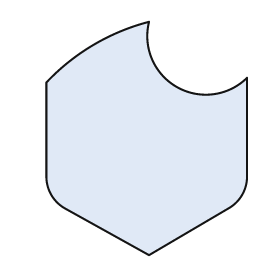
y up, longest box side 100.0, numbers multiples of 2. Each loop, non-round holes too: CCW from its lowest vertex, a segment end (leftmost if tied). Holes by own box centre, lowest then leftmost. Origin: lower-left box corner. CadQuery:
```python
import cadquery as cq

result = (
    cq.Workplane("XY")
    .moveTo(44.0, 0.0)
    .lineTo(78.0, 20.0)
    .threePointArc((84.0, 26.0), (86.0, 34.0))
    .lineTo(86.0, 76.0)
    .threePointArc((56.0, 72.0), (44.0, 100.0))
    .threePointArc((20.0, 90.0), (0.0, 74.0))
    .lineTo(0.0, 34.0)
    .threePointArc((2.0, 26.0), (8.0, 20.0))
    .close()
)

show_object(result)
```